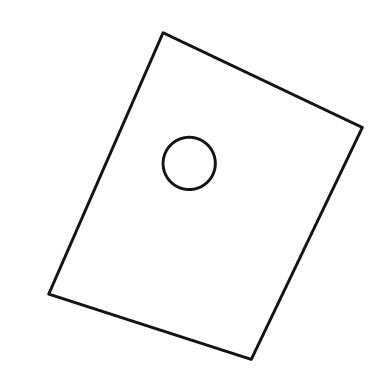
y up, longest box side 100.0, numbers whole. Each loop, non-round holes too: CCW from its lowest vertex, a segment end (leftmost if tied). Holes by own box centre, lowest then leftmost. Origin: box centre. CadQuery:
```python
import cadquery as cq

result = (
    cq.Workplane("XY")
    .moveTo(14.0, -50.0)
    .lineTo(48.0, 21.0)
    .lineTo(-13.0, 50.0)
    .lineTo(-48.0, -30.0)
    .close()
    .moveTo(-5.0, 10.0)
    .circle(8.0)
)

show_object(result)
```